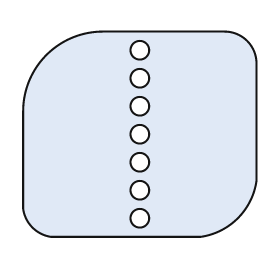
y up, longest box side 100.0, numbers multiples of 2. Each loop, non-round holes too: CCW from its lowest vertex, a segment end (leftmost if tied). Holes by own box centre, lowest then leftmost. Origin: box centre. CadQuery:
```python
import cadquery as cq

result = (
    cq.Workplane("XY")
    .moveTo(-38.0, -44.0)
    .lineTo(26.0, -44.0)
    .threePointArc((42.0, -36.0), (50.0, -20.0))
    .lineTo(50.0, 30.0)
    .threePointArc((46.0, 40.0), (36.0, 44.0))
    .lineTo(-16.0, 44.0)
    .threePointArc((-40.0, 34.0), (-50.0, 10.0))
    .lineTo(-50.0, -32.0)
    .threePointArc((-46.0, -40.0), (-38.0, -44.0))
    .close()
    .moveTo(0.0, -36.0)
    .circle(4.0)
    .moveTo(0.0, -24.0)
    .circle(4.0)
    .moveTo(0.0, -12.0)
    .circle(4.0)
    .moveTo(0.0, 0.0)
    .circle(4.0)
    .moveTo(0.0, 12.0)
    .circle(4.0)
    .moveTo(0.0, 24.0)
    .circle(4.0)
    .moveTo(0.0, 36.0)
    .circle(4.0)
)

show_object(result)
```